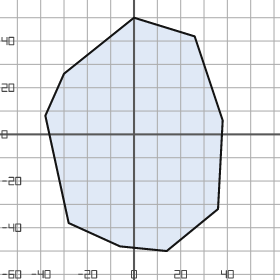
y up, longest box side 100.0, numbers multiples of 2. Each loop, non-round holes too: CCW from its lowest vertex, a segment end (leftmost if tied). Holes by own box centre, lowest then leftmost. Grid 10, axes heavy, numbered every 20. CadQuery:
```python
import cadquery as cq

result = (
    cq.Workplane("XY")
    .moveTo(14.0, -50.0)
    .lineTo(36.0, -32.0)
    .lineTo(38.0, 6.0)
    .lineTo(26.0, 42.0)
    .lineTo(0.0, 50.0)
    .lineTo(-30.0, 26.0)
    .lineTo(-38.0, 8.0)
    .lineTo(-28.0, -38.0)
    .lineTo(-6.0, -48.0)
    .close()
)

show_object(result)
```